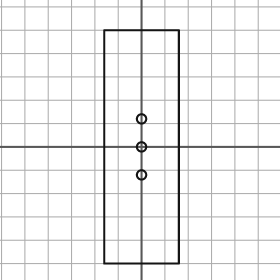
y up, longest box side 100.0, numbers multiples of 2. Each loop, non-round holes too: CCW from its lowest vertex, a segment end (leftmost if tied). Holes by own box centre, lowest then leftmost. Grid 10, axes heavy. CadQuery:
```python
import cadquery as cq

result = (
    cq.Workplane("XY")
    .moveTo(-16.0, -50.0)
    .lineTo(16.0, -50.0)
    .lineTo(16.0, 50.0)
    .lineTo(-16.0, 50.0)
    .close()
    .moveTo(0.0, -12.0)
    .circle(2.0)
    .moveTo(0.0, 0.0)
    .circle(2.0)
    .moveTo(0.0, 12.0)
    .circle(2.0)
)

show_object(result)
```